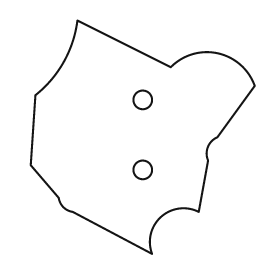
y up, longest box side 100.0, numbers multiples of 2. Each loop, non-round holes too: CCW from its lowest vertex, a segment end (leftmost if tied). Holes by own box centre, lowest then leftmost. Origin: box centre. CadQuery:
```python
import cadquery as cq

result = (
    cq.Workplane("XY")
    .moveTo(4.0, -50.0)
    .threePointArc((8.0, -34.0), (24.0, -32.0))
    .lineTo(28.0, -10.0)
    .threePointArc((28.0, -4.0), (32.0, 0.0))
    .lineTo(48.0, 22.0)
    .threePointArc((32.0, 36.0), (12.0, 30.0))
    .lineTo(-28.0, 50.0)
    .threePointArc((-34.0, 32.0), (-46.0, 18.0))
    .lineTo(-48.0, -12.0)
    .lineTo(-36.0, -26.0)
    .threePointArc((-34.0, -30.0), (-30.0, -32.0))
    .close()
    .moveTo(0.0, -14.0)
    .circle(4.0)
    .moveTo(0.0, 16.0)
    .circle(4.0)
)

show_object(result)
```